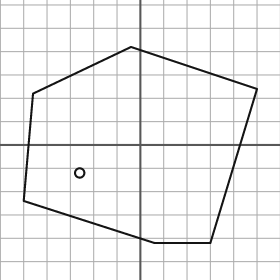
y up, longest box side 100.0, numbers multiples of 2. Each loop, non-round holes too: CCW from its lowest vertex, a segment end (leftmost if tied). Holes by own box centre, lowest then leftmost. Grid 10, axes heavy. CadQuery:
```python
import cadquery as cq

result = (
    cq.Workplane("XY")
    .moveTo(6.0, -42.0)
    .lineTo(30.0, -42.0)
    .lineTo(50.0, 24.0)
    .lineTo(-4.0, 42.0)
    .lineTo(-46.0, 22.0)
    .lineTo(-50.0, -24.0)
    .close()
    .moveTo(-26.0, -12.0)
    .circle(2.0)
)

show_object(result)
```